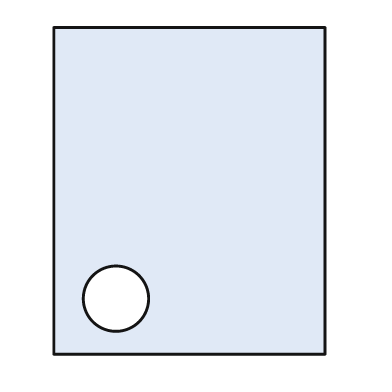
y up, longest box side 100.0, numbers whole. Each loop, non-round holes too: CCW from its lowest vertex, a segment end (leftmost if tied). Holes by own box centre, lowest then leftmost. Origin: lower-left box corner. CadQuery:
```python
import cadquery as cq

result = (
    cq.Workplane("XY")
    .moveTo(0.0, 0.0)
    .lineTo(83.0, 0.0)
    .lineTo(83.0, 100.0)
    .lineTo(0.0, 100.0)
    .close()
    .moveTo(19.0, 17.0)
    .circle(10.0)
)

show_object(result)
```